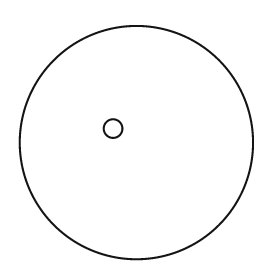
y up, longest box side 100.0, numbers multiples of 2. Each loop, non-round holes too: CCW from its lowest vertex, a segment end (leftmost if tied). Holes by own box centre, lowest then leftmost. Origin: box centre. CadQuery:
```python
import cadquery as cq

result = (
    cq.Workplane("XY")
    .moveTo(0.0, 0.0)
    .circle(50.0)
    .moveTo(-10.0, 6.0)
    .circle(4.0)
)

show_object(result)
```